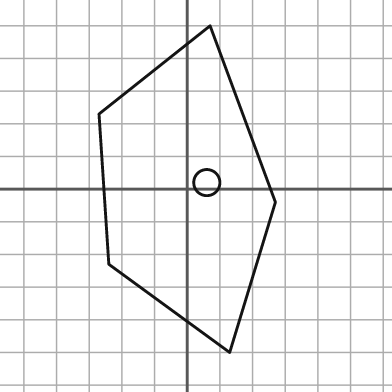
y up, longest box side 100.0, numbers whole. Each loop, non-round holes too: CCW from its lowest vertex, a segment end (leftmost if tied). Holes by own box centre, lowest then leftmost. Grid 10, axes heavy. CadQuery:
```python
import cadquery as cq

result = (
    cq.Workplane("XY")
    .moveTo(13.0, -50.0)
    .lineTo(27.0, -4.0)
    .lineTo(7.0, 50.0)
    .lineTo(-27.0, 23.0)
    .lineTo(-24.0, -23.0)
    .close()
    .moveTo(6.0, 2.0)
    .circle(4.0)
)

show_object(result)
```